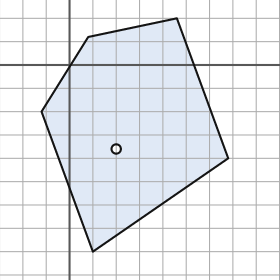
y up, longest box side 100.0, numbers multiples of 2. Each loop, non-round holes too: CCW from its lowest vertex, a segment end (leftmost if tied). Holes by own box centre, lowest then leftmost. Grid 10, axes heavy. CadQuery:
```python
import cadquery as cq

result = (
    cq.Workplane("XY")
    .moveTo(10.0, -80.0)
    .lineTo(68.0, -40.0)
    .lineTo(46.0, 20.0)
    .lineTo(8.0, 12.0)
    .lineTo(-12.0, -20.0)
    .close()
    .moveTo(20.0, -36.0)
    .circle(2.0)
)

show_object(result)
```